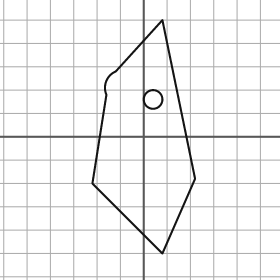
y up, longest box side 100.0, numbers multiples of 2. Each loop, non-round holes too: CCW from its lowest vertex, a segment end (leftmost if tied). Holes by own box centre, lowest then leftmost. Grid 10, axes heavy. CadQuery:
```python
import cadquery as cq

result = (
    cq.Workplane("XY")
    .moveTo(8.0, -50.0)
    .lineTo(22.0, -18.0)
    .lineTo(8.0, 50.0)
    .lineTo(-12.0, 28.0)
    .threePointArc((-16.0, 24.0), (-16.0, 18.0))
    .lineTo(-22.0, -20.0)
    .close()
    .moveTo(4.0, 16.0)
    .circle(4.0)
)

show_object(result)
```